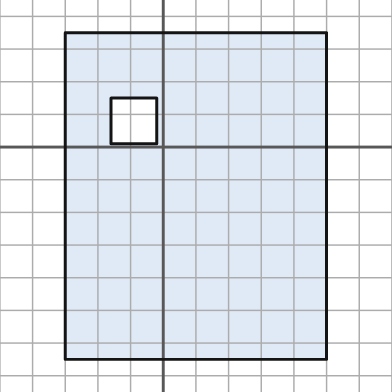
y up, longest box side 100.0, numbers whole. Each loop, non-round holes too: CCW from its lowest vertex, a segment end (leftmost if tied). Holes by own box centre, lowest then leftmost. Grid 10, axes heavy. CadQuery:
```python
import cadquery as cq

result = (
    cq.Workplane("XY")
    .moveTo(-30.0, -65.0)
    .lineTo(50.0, -65.0)
    .lineTo(50.0, 35.0)
    .lineTo(-30.0, 35.0)
    .close()
    .moveTo(-16.0, 1.0)
    .lineTo(-2.0, 1.0)
    .lineTo(-2.0, 15.0)
    .lineTo(-16.0, 15.0)
    .close()
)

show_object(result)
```